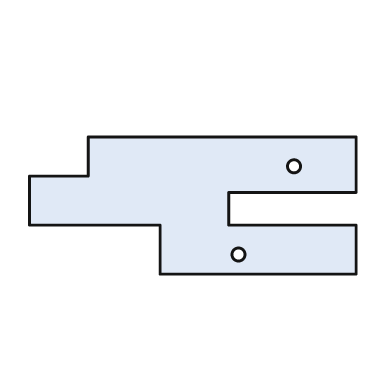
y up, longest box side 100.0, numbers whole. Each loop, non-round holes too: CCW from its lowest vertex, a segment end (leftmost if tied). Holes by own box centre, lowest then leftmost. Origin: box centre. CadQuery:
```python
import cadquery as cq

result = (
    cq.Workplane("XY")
    .moveTo(-10.0, -21.0)
    .lineTo(50.0, -21.0)
    .lineTo(50.0, -6.0)
    .lineTo(11.0, -6.0)
    .lineTo(11.0, 4.0)
    .lineTo(50.0, 4.0)
    .lineTo(50.0, 21.0)
    .lineTo(-32.0, 21.0)
    .lineTo(-32.0, 9.0)
    .lineTo(-50.0, 9.0)
    .lineTo(-50.0, -6.0)
    .lineTo(-10.0, -6.0)
    .close()
    .moveTo(14.0, -15.0)
    .circle(2.0)
    .moveTo(31.0, 12.0)
    .circle(2.0)
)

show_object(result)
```